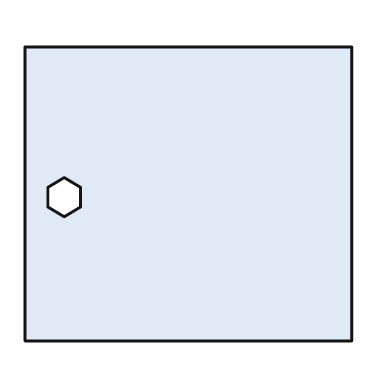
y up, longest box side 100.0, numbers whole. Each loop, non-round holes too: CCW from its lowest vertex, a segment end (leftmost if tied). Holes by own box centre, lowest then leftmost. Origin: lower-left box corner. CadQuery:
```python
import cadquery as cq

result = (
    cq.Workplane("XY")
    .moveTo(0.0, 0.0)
    .lineTo(100.0, 0.0)
    .lineTo(100.0, 90.0)
    .lineTo(0.0, 90.0)
    .close()
    .moveTo(12.0, 38.0)
    .lineTo(17.0, 41.0)
    .lineTo(17.0, 47.0)
    .lineTo(12.0, 50.0)
    .lineTo(7.0, 47.0)
    .lineTo(7.0, 41.0)
    .close()
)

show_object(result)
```